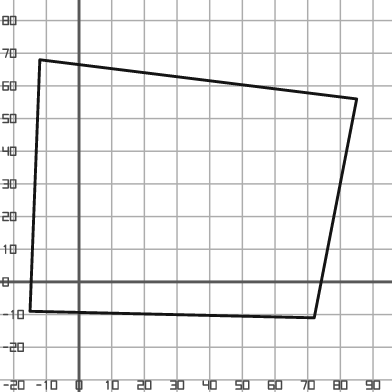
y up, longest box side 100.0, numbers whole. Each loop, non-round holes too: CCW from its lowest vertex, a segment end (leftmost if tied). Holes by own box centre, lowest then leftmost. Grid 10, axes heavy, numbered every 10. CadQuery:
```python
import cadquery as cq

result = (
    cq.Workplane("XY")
    .moveTo(72.0, -11.0)
    .lineTo(85.0, 56.0)
    .lineTo(-12.0, 68.0)
    .lineTo(-15.0, -9.0)
    .close()
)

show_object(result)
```